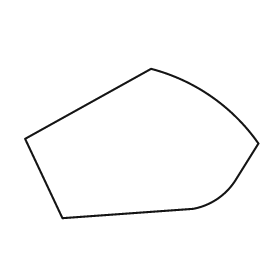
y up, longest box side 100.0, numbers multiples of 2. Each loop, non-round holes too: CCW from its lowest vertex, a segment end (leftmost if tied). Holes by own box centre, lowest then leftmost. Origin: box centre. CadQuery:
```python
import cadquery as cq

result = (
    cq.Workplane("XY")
    .moveTo(-34.0, -32.0)
    .lineTo(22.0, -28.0)
    .threePointArc((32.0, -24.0), (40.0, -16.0))
    .lineTo(50.0, 0.0)
    .threePointArc((30.0, 20.0), (4.0, 32.0))
    .lineTo(-50.0, 2.0)
    .close()
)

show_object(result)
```